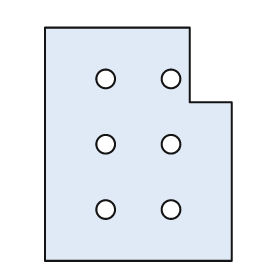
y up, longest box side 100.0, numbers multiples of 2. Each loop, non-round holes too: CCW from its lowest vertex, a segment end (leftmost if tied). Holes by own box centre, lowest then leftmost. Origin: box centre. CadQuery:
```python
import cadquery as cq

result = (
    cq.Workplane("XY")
    .moveTo(-40.0, -50.0)
    .lineTo(40.0, -50.0)
    .lineTo(40.0, 18.0)
    .lineTo(22.0, 18.0)
    .lineTo(22.0, 50.0)
    .lineTo(-40.0, 50.0)
    .close()
    .moveTo(-14.0, -28.0)
    .circle(4.0)
    .moveTo(14.0, -28.0)
    .circle(4.0)
    .moveTo(-14.0, 0.0)
    .circle(4.0)
    .moveTo(14.0, 0.0)
    .circle(4.0)
    .moveTo(-14.0, 28.0)
    .circle(4.0)
    .moveTo(14.0, 28.0)
    .circle(4.0)
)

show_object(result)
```